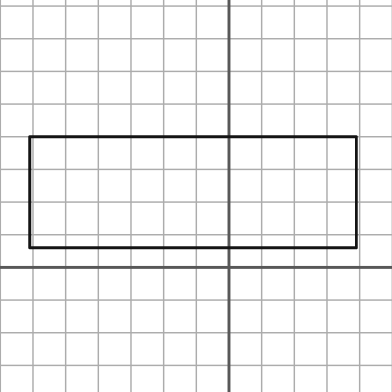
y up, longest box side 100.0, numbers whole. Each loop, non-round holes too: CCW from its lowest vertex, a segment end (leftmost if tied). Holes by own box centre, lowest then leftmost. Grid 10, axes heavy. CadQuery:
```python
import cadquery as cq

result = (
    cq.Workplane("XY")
    .moveTo(-61.0, 6.0)
    .lineTo(39.0, 6.0)
    .lineTo(39.0, 40.0)
    .lineTo(-61.0, 40.0)
    .close()
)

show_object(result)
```